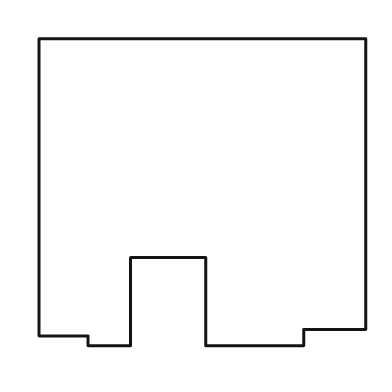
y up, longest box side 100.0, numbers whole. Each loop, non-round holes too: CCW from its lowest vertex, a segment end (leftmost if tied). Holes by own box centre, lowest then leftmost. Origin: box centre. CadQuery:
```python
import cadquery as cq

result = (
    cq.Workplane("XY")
    .moveTo(-35.0, -47.0)
    .lineTo(-22.0, -47.0)
    .lineTo(-22.0, -20.0)
    .lineTo(1.0, -20.0)
    .lineTo(1.0, -47.0)
    .lineTo(31.0, -47.0)
    .lineTo(31.0, -42.0)
    .lineTo(50.0, -42.0)
    .lineTo(50.0, 47.0)
    .lineTo(-50.0, 47.0)
    .lineTo(-50.0, -44.0)
    .lineTo(-35.0, -44.0)
    .close()
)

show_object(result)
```